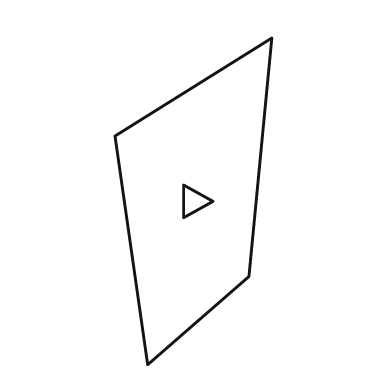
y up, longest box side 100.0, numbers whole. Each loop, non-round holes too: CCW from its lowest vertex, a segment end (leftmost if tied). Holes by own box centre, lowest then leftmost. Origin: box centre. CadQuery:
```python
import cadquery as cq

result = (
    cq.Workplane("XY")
    .moveTo(-14.0, -50.0)
    .lineTo(17.0, -23.0)
    .lineTo(24.0, 50.0)
    .lineTo(-24.0, 20.0)
    .close()
    .moveTo(-3.0, -5.0)
    .lineTo(6.0, 0.0)
    .lineTo(-3.0, 5.0)
    .close()
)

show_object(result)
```